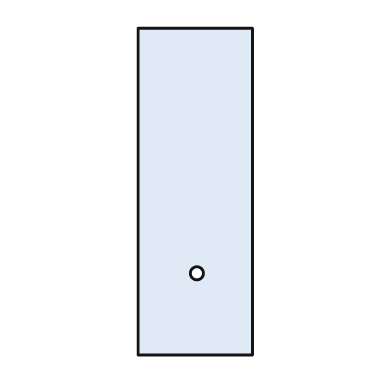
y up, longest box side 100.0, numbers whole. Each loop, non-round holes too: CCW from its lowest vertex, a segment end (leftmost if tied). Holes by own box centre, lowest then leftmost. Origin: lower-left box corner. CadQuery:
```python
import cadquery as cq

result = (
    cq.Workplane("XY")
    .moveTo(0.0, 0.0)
    .lineTo(35.0, 0.0)
    .lineTo(35.0, 100.0)
    .lineTo(0.0, 100.0)
    .close()
    .moveTo(18.0, 25.0)
    .circle(2.0)
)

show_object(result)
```